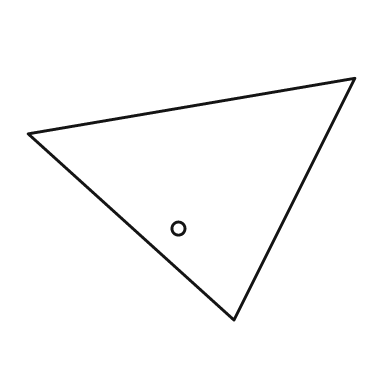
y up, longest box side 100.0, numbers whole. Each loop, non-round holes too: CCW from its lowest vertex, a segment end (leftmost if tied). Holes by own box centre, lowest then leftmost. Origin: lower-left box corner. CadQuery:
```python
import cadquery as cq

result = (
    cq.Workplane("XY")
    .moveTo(63.0, 0.0)
    .lineTo(100.0, 74.0)
    .lineTo(0.0, 57.0)
    .close()
    .moveTo(46.0, 28.0)
    .circle(2.0)
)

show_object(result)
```